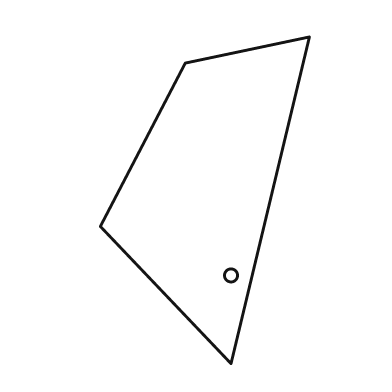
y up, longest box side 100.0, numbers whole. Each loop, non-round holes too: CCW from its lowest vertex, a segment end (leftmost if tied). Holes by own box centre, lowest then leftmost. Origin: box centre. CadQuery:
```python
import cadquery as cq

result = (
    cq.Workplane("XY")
    .moveTo(8.0, -50.0)
    .lineTo(32.0, 50.0)
    .lineTo(-6.0, 42.0)
    .lineTo(-32.0, -8.0)
    .close()
    .moveTo(8.0, -23.0)
    .circle(2.0)
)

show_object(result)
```